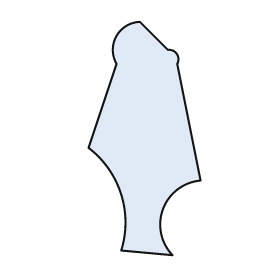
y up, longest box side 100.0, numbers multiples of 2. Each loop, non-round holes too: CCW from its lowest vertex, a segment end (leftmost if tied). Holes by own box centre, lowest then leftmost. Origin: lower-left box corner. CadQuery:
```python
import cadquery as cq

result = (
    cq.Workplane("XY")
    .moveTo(36.0, 0.0)
    .threePointArc((32.0, 20.0), (48.0, 32.0))
    .lineTo(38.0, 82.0)
    .threePointArc((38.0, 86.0), (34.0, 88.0))
    .lineTo(22.0, 100.0)
    .threePointArc((12.0, 94.0), (12.0, 82.0))
    .lineTo(0.0, 46.0)
    .threePointArc((14.0, 26.0), (14.0, 2.0))
    .close()
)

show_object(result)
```